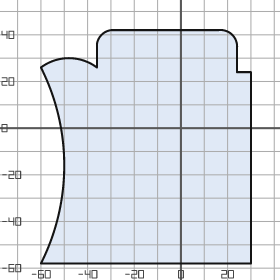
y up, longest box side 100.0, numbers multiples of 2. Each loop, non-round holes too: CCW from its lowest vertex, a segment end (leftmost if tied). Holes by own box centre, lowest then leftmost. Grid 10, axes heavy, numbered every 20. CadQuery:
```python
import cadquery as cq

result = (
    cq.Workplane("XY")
    .moveTo(-60.0, -58.0)
    .lineTo(30.0, -58.0)
    .lineTo(30.0, 24.0)
    .lineTo(24.0, 24.0)
    .lineTo(24.0, 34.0)
    .threePointArc((22.0, 40.0), (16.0, 42.0))
    .lineTo(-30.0, 42.0)
    .threePointArc((-34.0, 40.0), (-36.0, 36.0))
    .lineTo(-36.0, 26.0)
    .threePointArc((-48.0, 30.0), (-60.0, 26.0))
    .threePointArc((-50.0, -16.0), (-60.0, -58.0))
    .close()
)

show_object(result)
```